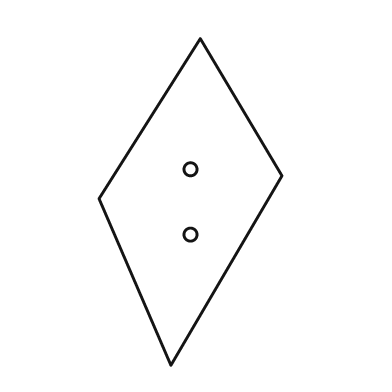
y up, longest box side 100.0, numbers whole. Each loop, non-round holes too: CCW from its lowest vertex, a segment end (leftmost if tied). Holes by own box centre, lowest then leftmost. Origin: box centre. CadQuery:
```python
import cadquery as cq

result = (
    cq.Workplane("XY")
    .moveTo(-6.0, -50.0)
    .lineTo(28.0, 8.0)
    .lineTo(3.0, 50.0)
    .lineTo(-28.0, 1.0)
    .close()
    .moveTo(0.0, -10.0)
    .circle(2.0)
    .moveTo(0.0, 10.0)
    .circle(2.0)
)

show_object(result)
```